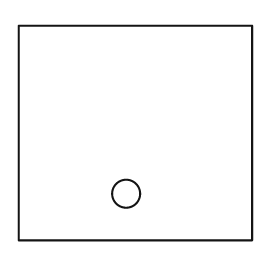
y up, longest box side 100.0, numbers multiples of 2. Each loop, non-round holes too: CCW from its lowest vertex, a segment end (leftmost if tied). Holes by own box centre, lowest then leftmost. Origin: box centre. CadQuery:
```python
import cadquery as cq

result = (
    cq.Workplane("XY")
    .moveTo(-50.0, -46.0)
    .lineTo(50.0, -46.0)
    .lineTo(50.0, 46.0)
    .lineTo(-50.0, 46.0)
    .close()
    .moveTo(-4.0, -26.0)
    .circle(6.0)
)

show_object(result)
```